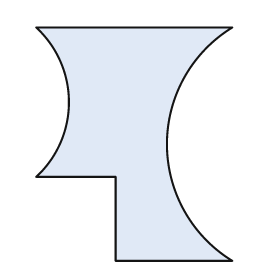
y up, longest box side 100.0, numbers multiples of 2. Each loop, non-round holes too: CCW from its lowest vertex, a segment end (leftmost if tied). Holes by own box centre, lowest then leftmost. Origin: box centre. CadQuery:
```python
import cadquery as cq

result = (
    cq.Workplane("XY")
    .moveTo(-8.0, -50.0)
    .lineTo(42.0, -50.0)
    .threePointArc((14.0, 0.0), (42.0, 50.0))
    .lineTo(-42.0, 50.0)
    .threePointArc((-28.0, 18.0), (-42.0, -14.0))
    .lineTo(-8.0, -14.0)
    .close()
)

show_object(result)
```